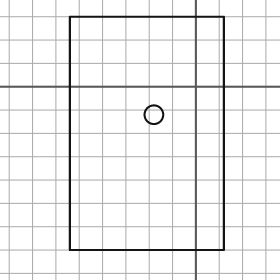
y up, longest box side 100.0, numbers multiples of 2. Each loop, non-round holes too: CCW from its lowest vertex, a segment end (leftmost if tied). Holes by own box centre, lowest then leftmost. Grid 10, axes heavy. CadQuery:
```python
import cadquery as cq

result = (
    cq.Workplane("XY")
    .moveTo(-54.0, -70.0)
    .lineTo(12.0, -70.0)
    .lineTo(12.0, 30.0)
    .lineTo(-54.0, 30.0)
    .close()
    .moveTo(-18.0, -12.0)
    .circle(4.0)
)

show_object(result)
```